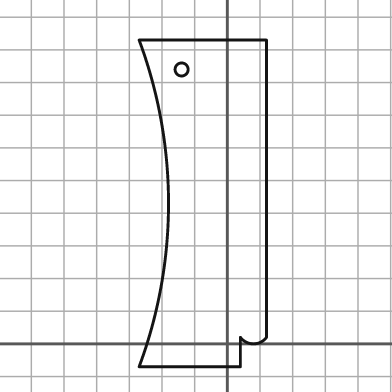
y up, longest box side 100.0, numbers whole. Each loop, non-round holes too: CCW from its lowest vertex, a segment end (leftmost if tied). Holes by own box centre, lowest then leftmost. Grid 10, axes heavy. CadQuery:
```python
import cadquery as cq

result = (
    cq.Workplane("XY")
    .moveTo(-27.0, -7.0)
    .lineTo(4.0, -7.0)
    .lineTo(4.0, 2.0)
    .threePointArc((8.0, 0.0), (12.0, 2.0))
    .lineTo(12.0, 93.0)
    .lineTo(-27.0, 93.0)
    .threePointArc((-18.0, 43.0), (-27.0, -7.0))
    .close()
    .moveTo(-14.0, 84.0)
    .circle(2.0)
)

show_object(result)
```